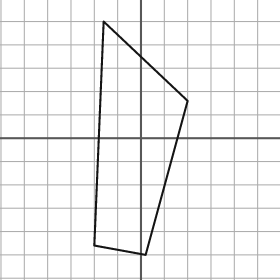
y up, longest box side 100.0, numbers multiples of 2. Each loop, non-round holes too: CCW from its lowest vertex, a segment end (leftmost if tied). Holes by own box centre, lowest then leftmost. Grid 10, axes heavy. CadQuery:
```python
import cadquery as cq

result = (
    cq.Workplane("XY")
    .moveTo(2.0, -50.0)
    .lineTo(20.0, 16.0)
    .lineTo(-16.0, 50.0)
    .lineTo(-20.0, -46.0)
    .close()
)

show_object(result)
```